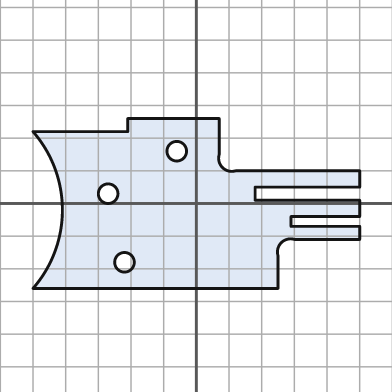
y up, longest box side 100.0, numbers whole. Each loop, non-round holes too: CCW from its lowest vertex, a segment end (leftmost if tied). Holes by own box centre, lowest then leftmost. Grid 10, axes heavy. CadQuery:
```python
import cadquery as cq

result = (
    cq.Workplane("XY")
    .moveTo(-50.0, -26.0)
    .lineTo(25.0, -26.0)
    .lineTo(25.0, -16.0)
    .threePointArc((26.0, -12.0), (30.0, -11.0))
    .lineTo(50.0, -11.0)
    .lineTo(50.0, -7.0)
    .lineTo(29.0, -7.0)
    .lineTo(29.0, -4.0)
    .lineTo(50.0, -4.0)
    .lineTo(50.0, 1.0)
    .lineTo(18.0, 1.0)
    .lineTo(18.0, 5.0)
    .lineTo(50.0, 5.0)
    .lineTo(50.0, 10.0)
    .lineTo(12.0, 10.0)
    .threePointArc((8.0, 11.0), (7.0, 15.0))
    .lineTo(7.0, 26.0)
    .lineTo(-21.0, 26.0)
    .lineTo(-21.0, 22.0)
    .lineTo(-50.0, 22.0)
    .threePointArc((-41.0, -2.0), (-50.0, -26.0))
    .close()
    .moveTo(-22.0, -18.0)
    .circle(3.0)
    .moveTo(-27.0, 3.0)
    .circle(3.0)
    .moveTo(-6.0, 16.0)
    .circle(3.0)
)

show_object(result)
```